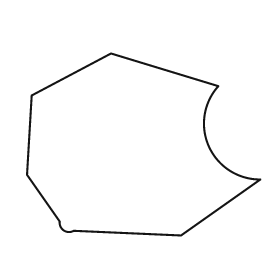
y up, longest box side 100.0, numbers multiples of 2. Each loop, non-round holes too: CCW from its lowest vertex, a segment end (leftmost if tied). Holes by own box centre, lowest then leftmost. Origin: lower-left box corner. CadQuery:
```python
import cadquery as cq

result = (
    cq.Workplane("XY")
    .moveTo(66.0, 0.0)
    .lineTo(100.0, 24.0)
    .threePointArc((78.0, 38.0), (82.0, 64.0))
    .lineTo(36.0, 78.0)
    .lineTo(2.0, 60.0)
    .lineTo(0.0, 26.0)
    .lineTo(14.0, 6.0)
    .threePointArc((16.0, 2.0), (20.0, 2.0))
    .close()
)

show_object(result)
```